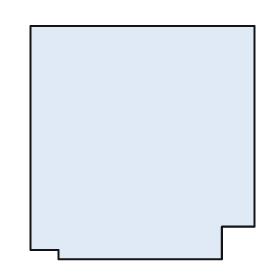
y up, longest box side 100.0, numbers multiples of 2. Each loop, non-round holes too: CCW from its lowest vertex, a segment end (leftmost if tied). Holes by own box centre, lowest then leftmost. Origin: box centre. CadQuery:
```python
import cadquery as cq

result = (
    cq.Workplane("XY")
    .moveTo(-36.0, -50.0)
    .lineTo(34.0, -50.0)
    .lineTo(34.0, -36.0)
    .lineTo(48.0, -36.0)
    .lineTo(48.0, 50.0)
    .lineTo(-48.0, 50.0)
    .lineTo(-48.0, -46.0)
    .lineTo(-36.0, -46.0)
    .close()
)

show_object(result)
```